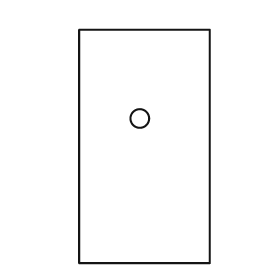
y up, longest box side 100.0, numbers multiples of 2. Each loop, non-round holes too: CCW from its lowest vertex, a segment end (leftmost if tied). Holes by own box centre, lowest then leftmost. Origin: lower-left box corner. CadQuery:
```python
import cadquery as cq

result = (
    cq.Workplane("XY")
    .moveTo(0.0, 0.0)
    .lineTo(56.0, 0.0)
    .lineTo(56.0, 100.0)
    .lineTo(0.0, 100.0)
    .close()
    .moveTo(26.0, 62.0)
    .circle(4.0)
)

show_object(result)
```